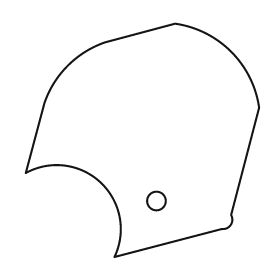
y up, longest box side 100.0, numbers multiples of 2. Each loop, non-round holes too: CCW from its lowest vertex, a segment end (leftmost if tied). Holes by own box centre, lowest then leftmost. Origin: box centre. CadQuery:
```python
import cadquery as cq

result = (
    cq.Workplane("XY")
    .moveTo(-12.0, -50.0)
    .lineTo(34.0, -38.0)
    .threePointArc((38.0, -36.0), (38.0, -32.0))
    .lineTo(50.0, 14.0)
    .threePointArc((38.0, 38.0), (14.0, 50.0))
    .lineTo(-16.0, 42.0)
    .threePointArc((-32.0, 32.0), (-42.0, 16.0))
    .lineTo(-50.0, -14.0)
    .threePointArc((-18.0, -18.0), (-12.0, -50.0))
    .close()
    .moveTo(6.0, -26.0)
    .circle(4.0)
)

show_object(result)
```